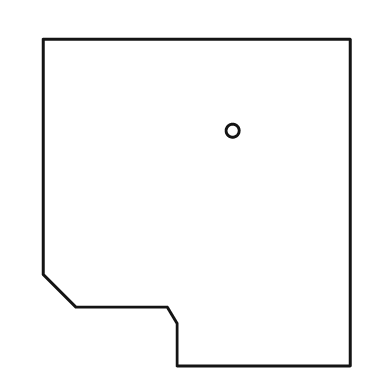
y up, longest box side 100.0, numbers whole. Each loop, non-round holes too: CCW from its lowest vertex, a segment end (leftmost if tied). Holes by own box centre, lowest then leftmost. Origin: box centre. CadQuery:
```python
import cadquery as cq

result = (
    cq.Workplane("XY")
    .moveTo(-6.0, -50.0)
    .lineTo(47.0, -50.0)
    .lineTo(47.0, 50.0)
    .lineTo(-47.0, 50.0)
    .lineTo(-47.0, -22.0)
    .lineTo(-37.0, -32.0)
    .lineTo(-9.0, -32.0)
    .lineTo(-6.0, -37.0)
    .close()
    .moveTo(11.0, 22.0)
    .circle(2.0)
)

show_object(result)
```